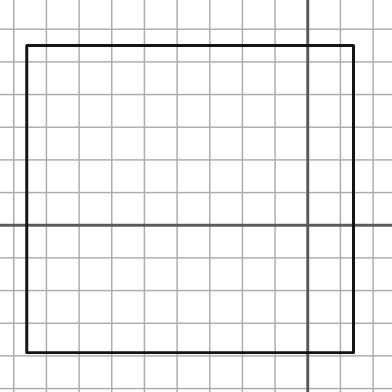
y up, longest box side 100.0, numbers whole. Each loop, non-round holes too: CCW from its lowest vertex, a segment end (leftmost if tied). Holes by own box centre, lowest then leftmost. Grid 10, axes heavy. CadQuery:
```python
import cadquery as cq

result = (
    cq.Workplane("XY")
    .moveTo(-86.0, -39.0)
    .lineTo(14.0, -39.0)
    .lineTo(14.0, 55.0)
    .lineTo(-86.0, 55.0)
    .close()
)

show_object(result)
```